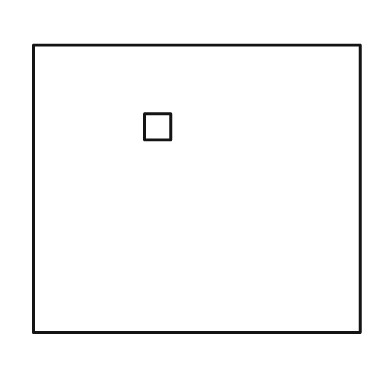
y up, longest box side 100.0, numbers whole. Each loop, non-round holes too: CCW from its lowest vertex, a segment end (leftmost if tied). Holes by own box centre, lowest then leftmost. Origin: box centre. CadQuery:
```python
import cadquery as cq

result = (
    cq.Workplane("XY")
    .moveTo(-50.0, -44.0)
    .lineTo(50.0, -44.0)
    .lineTo(50.0, 44.0)
    .lineTo(-50.0, 44.0)
    .close()
    .moveTo(-16.0, 15.0)
    .lineTo(-8.0, 15.0)
    .lineTo(-8.0, 23.0)
    .lineTo(-16.0, 23.0)
    .close()
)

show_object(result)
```